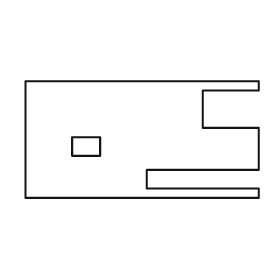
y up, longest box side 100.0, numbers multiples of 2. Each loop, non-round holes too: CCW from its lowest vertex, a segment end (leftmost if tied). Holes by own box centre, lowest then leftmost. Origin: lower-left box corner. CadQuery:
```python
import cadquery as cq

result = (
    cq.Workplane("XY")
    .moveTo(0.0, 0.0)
    .lineTo(100.0, 0.0)
    .lineTo(100.0, 4.0)
    .lineTo(52.0, 4.0)
    .lineTo(52.0, 12.0)
    .lineTo(100.0, 12.0)
    .lineTo(100.0, 30.0)
    .lineTo(76.0, 30.0)
    .lineTo(76.0, 46.0)
    .lineTo(100.0, 46.0)
    .lineTo(100.0, 50.0)
    .lineTo(0.0, 50.0)
    .close()
    .moveTo(20.0, 18.0)
    .lineTo(32.0, 18.0)
    .lineTo(32.0, 26.0)
    .lineTo(20.0, 26.0)
    .close()
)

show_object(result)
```